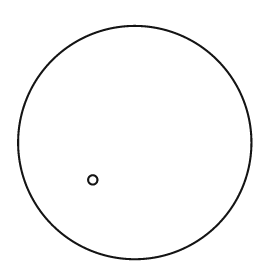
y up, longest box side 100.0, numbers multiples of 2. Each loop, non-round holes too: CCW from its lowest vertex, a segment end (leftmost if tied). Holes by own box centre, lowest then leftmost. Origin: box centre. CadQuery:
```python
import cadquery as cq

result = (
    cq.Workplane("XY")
    .moveTo(0.0, 0.0)
    .circle(50.0)
    .moveTo(-18.0, -16.0)
    .circle(2.0)
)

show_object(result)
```